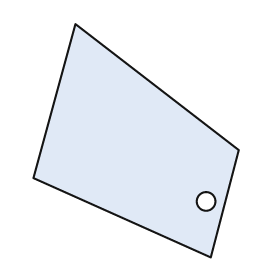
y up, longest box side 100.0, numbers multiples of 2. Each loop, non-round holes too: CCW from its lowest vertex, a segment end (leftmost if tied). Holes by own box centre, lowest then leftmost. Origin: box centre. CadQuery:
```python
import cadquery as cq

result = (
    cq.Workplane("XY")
    .moveTo(32.0, -50.0)
    .lineTo(44.0, -4.0)
    .lineTo(-26.0, 50.0)
    .lineTo(-44.0, -16.0)
    .close()
    .moveTo(30.0, -26.0)
    .circle(4.0)
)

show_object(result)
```